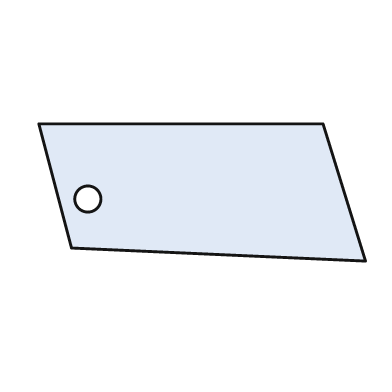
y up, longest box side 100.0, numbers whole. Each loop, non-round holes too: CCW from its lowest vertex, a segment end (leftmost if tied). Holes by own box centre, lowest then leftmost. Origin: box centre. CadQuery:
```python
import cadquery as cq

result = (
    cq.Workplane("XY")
    .moveTo(50.0, -21.0)
    .lineTo(37.0, 21.0)
    .lineTo(-50.0, 21.0)
    .lineTo(-40.0, -17.0)
    .close()
    .moveTo(-35.0, -2.0)
    .circle(4.0)
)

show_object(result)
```